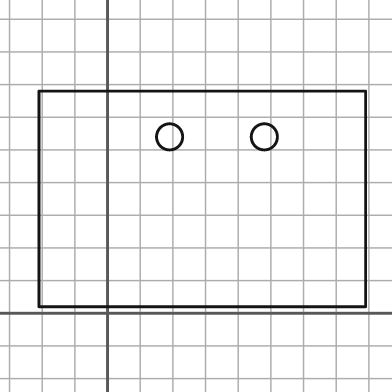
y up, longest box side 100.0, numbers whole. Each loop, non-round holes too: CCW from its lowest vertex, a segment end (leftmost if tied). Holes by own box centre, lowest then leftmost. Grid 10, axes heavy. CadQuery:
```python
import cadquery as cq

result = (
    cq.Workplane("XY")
    .moveTo(-21.0, 2.0)
    .lineTo(79.0, 2.0)
    .lineTo(79.0, 68.0)
    .lineTo(-21.0, 68.0)
    .close()
    .moveTo(19.0, 54.0)
    .circle(4.0)
    .moveTo(48.0, 54.0)
    .circle(4.0)
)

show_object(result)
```